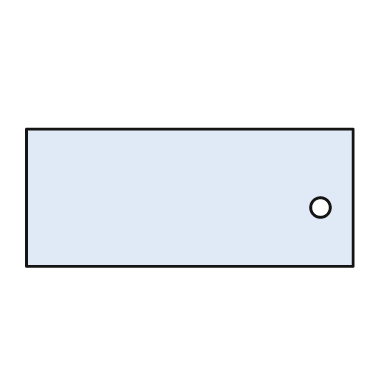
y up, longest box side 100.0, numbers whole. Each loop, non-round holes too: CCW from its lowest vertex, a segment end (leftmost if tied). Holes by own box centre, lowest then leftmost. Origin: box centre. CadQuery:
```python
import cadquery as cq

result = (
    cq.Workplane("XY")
    .moveTo(-50.0, -21.0)
    .lineTo(50.0, -21.0)
    .lineTo(50.0, 21.0)
    .lineTo(-50.0, 21.0)
    .close()
    .moveTo(40.0, -3.0)
    .circle(3.0)
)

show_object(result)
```